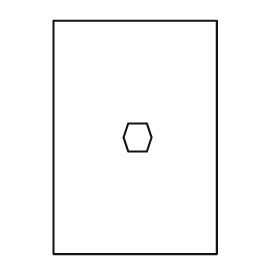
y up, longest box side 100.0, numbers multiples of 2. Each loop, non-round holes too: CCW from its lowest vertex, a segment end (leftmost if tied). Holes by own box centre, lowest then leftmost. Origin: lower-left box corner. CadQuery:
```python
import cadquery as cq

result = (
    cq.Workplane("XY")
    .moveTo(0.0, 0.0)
    .lineTo(70.0, 0.0)
    .lineTo(70.0, 100.0)
    .lineTo(0.0, 100.0)
    .close()
    .moveTo(32.0, 44.0)
    .lineTo(40.0, 44.0)
    .lineTo(42.0, 50.0)
    .lineTo(40.0, 56.0)
    .lineTo(32.0, 56.0)
    .lineTo(30.0, 50.0)
    .close()
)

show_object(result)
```